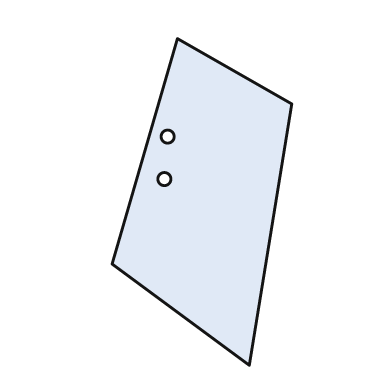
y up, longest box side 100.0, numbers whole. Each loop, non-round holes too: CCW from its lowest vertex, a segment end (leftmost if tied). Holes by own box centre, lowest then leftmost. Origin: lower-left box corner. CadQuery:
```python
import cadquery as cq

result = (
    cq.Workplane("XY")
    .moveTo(42.0, 0.0)
    .lineTo(55.0, 80.0)
    .lineTo(20.0, 100.0)
    .lineTo(0.0, 31.0)
    .close()
    .moveTo(16.0, 57.0)
    .circle(2.0)
    .moveTo(17.0, 70.0)
    .circle(2.0)
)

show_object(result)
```